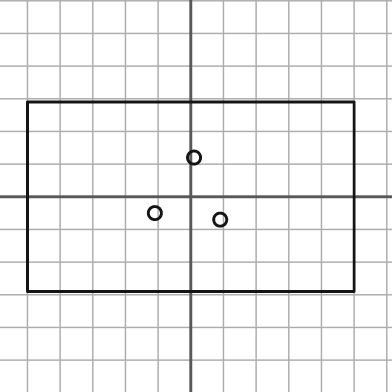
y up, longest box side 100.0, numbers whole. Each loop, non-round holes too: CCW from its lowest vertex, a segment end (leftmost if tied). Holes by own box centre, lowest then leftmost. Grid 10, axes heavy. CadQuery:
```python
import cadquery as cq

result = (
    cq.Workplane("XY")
    .moveTo(-50.0, -29.0)
    .lineTo(50.0, -29.0)
    .lineTo(50.0, 29.0)
    .lineTo(-50.0, 29.0)
    .close()
    .moveTo(9.0, -7.0)
    .circle(2.0)
    .moveTo(-11.0, -5.0)
    .circle(2.0)
    .moveTo(1.0, 12.0)
    .circle(2.0)
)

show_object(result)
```